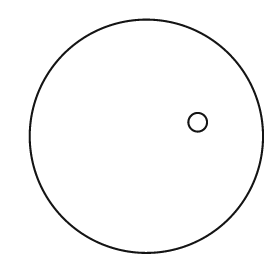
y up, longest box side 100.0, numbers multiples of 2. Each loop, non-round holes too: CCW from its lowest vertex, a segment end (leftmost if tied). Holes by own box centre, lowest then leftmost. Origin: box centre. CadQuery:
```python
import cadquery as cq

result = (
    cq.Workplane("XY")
    .moveTo(0.0, 0.0)
    .circle(50.0)
    .moveTo(22.0, 6.0)
    .circle(4.0)
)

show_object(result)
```